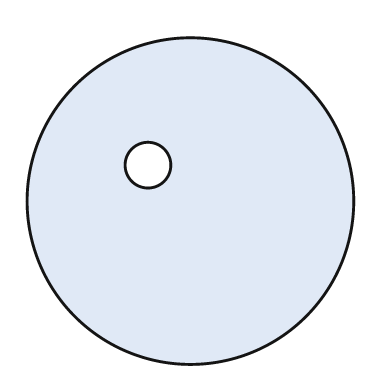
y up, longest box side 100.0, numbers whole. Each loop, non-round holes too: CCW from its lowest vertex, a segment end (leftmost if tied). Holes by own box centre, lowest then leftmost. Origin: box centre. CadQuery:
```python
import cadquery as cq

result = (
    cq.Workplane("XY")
    .moveTo(0.0, 0.0)
    .circle(50.0)
    .moveTo(-13.0, 11.0)
    .circle(7.0)
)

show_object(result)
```